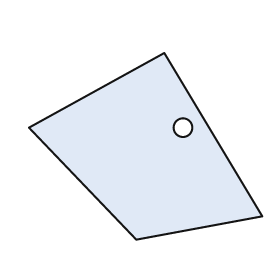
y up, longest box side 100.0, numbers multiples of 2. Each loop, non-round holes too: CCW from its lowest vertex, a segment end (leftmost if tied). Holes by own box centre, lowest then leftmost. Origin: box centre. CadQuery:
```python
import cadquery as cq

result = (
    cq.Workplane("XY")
    .moveTo(-4.0, -40.0)
    .lineTo(50.0, -30.0)
    .lineTo(8.0, 40.0)
    .lineTo(-50.0, 8.0)
    .close()
    .moveTo(16.0, 8.0)
    .circle(4.0)
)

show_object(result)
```